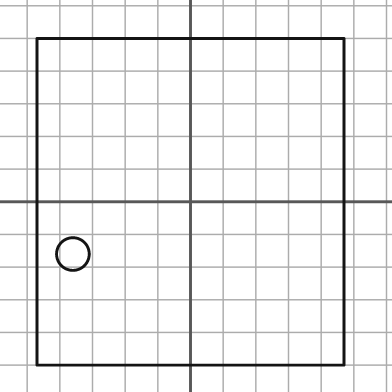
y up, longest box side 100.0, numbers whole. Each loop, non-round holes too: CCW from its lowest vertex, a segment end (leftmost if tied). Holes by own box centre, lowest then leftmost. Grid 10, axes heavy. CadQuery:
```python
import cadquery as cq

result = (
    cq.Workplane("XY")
    .moveTo(-47.0, -50.0)
    .lineTo(47.0, -50.0)
    .lineTo(47.0, 50.0)
    .lineTo(-47.0, 50.0)
    .close()
    .moveTo(-36.0, -16.0)
    .circle(5.0)
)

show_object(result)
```